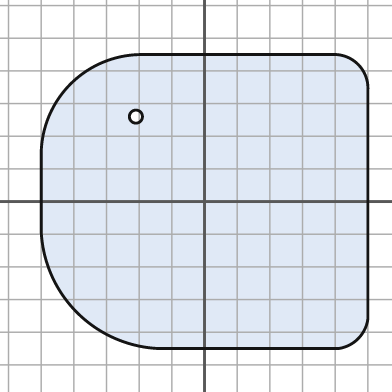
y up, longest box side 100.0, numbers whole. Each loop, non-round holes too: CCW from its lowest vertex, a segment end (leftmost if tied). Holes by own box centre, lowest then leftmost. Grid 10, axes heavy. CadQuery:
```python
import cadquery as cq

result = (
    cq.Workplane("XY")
    .moveTo(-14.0, -45.0)
    .lineTo(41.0, -45.0)
    .threePointArc((47.0, -42.0), (50.0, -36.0))
    .lineTo(50.0, 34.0)
    .threePointArc((47.0, 42.0), (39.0, 45.0))
    .lineTo(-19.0, 45.0)
    .threePointArc((-41.0, 36.0), (-50.0, 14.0))
    .lineTo(-50.0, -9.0)
    .threePointArc((-39.0, -34.0), (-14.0, -45.0))
    .close()
    .moveTo(-21.0, 26.0)
    .circle(2.0)
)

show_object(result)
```